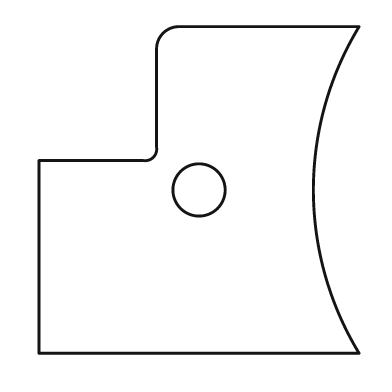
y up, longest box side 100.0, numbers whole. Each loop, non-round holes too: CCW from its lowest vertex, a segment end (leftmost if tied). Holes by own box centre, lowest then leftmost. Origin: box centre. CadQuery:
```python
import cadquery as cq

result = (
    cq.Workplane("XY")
    .moveTo(-49.0, -50.0)
    .lineTo(49.0, -50.0)
    .threePointArc((35.0, 0.0), (49.0, 50.0))
    .lineTo(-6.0, 50.0)
    .threePointArc((-11.0, 48.0), (-13.0, 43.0))
    .lineTo(-13.0, 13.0)
    .threePointArc((-14.0, 10.0), (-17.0, 9.0))
    .lineTo(-49.0, 9.0)
    .close()
    .moveTo(0.0, 0.0)
    .circle(8.0)
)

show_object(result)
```